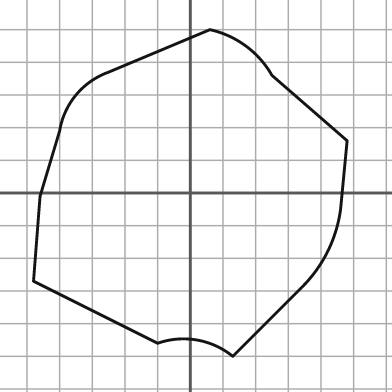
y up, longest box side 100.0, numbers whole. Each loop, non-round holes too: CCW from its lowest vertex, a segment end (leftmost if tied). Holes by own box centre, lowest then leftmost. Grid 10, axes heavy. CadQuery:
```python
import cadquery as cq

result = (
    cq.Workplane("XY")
    .moveTo(13.0, -50.0)
    .lineTo(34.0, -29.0)
    .threePointArc((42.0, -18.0), (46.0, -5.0))
    .lineTo(48.0, 16.0)
    .lineTo(25.0, 36.0)
    .threePointArc((17.0, 45.0), (6.0, 50.0))
    .lineTo(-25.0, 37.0)
    .threePointArc((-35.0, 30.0), (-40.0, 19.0))
    .lineTo(-46.0, -1.0)
    .lineTo(-48.0, -27.0)
    .lineTo(-10.0, -46.0)
    .threePointArc((2.0, -45.0), (13.0, -50.0))
    .close()
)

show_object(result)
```